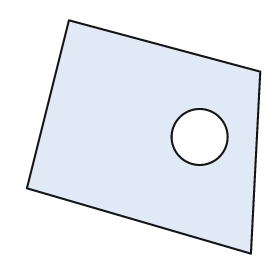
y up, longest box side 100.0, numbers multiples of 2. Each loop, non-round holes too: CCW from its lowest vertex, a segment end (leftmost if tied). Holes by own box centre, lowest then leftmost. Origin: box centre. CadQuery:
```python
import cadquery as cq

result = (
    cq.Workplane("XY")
    .moveTo(46.0, -50.0)
    .lineTo(50.0, 28.0)
    .lineTo(-32.0, 50.0)
    .lineTo(-50.0, -22.0)
    .close()
    .moveTo(24.0, 0.0)
    .circle(12.0)
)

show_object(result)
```